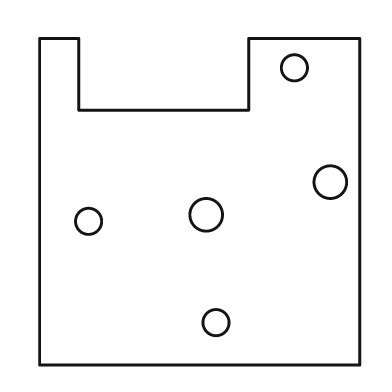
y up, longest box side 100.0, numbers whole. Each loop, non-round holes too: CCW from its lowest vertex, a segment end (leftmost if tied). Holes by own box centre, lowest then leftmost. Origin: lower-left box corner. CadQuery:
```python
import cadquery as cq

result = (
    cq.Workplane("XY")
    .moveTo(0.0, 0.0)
    .lineTo(98.0, 0.0)
    .lineTo(98.0, 100.0)
    .lineTo(64.0, 100.0)
    .lineTo(64.0, 78.0)
    .lineTo(12.0, 78.0)
    .lineTo(12.0, 100.0)
    .lineTo(0.0, 100.0)
    .close()
    .moveTo(54.0, 13.0)
    .circle(4.0)
    .moveTo(15.0, 44.0)
    .circle(4.0)
    .moveTo(51.0, 46.0)
    .circle(5.0)
    .moveTo(89.0, 56.0)
    .circle(5.0)
    .moveTo(78.0, 91.0)
    .circle(4.0)
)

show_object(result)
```